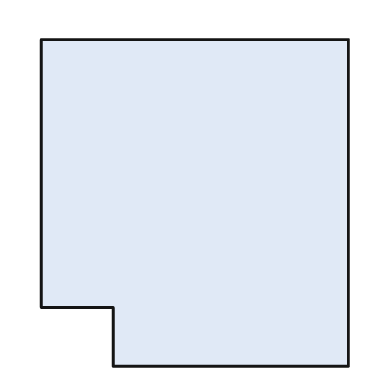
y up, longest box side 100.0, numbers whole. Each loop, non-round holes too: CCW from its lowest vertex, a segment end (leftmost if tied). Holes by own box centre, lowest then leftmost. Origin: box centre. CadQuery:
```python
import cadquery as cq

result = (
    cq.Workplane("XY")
    .moveTo(-25.0, -50.0)
    .lineTo(47.0, -50.0)
    .lineTo(47.0, 50.0)
    .lineTo(-47.0, 50.0)
    .lineTo(-47.0, -32.0)
    .lineTo(-25.0, -32.0)
    .close()
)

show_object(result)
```